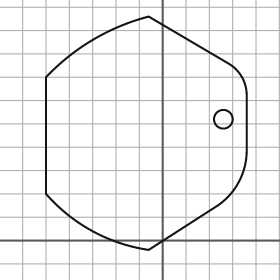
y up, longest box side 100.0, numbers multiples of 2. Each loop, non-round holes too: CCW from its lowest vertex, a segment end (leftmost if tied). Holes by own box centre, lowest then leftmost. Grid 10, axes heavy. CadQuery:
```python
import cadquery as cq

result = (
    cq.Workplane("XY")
    .moveTo(-6.0, -4.0)
    .lineTo(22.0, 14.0)
    .threePointArc((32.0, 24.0), (36.0, 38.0))
    .lineTo(36.0, 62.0)
    .threePointArc((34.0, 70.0), (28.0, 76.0))
    .lineTo(-6.0, 96.0)
    .threePointArc((-30.0, 86.0), (-50.0, 70.0))
    .lineTo(-50.0, 20.0)
    .threePointArc((-30.0, 4.0), (-6.0, -4.0))
    .close()
    .moveTo(26.0, 52.0)
    .circle(4.0)
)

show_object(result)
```